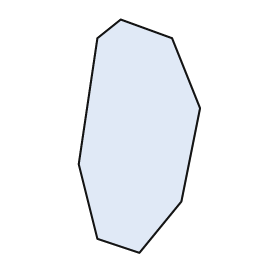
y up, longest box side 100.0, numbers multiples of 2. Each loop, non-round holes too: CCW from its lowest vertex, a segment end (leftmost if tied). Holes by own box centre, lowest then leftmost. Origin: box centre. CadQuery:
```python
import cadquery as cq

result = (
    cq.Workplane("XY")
    .moveTo(0.0, -50.0)
    .lineTo(18.0, -28.0)
    .lineTo(26.0, 12.0)
    .lineTo(14.0, 42.0)
    .lineTo(-8.0, 50.0)
    .lineTo(-18.0, 42.0)
    .lineTo(-26.0, -12.0)
    .lineTo(-18.0, -44.0)
    .close()
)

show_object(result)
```